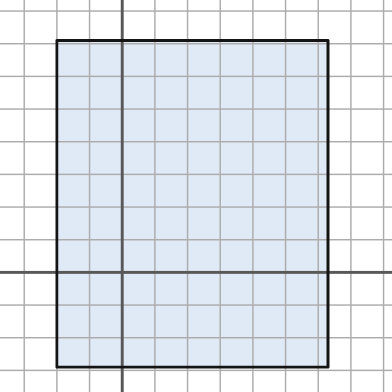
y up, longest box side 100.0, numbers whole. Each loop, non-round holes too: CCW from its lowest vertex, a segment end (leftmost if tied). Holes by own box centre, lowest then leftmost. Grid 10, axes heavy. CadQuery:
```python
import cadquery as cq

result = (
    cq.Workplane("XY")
    .moveTo(-20.0, -29.0)
    .lineTo(63.0, -29.0)
    .lineTo(63.0, 71.0)
    .lineTo(-20.0, 71.0)
    .close()
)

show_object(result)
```